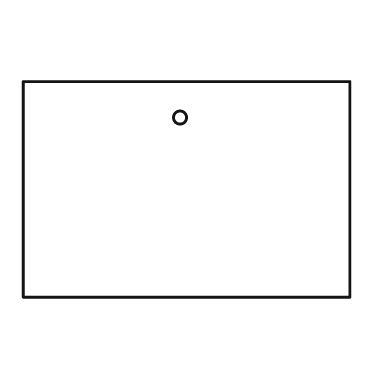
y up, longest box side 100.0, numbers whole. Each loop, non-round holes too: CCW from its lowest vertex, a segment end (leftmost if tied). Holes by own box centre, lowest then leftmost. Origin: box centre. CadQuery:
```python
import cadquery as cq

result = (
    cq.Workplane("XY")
    .moveTo(-50.0, -33.0)
    .lineTo(50.0, -33.0)
    .lineTo(50.0, 33.0)
    .lineTo(-50.0, 33.0)
    .close()
    .moveTo(-2.0, 22.0)
    .circle(2.0)
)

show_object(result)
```